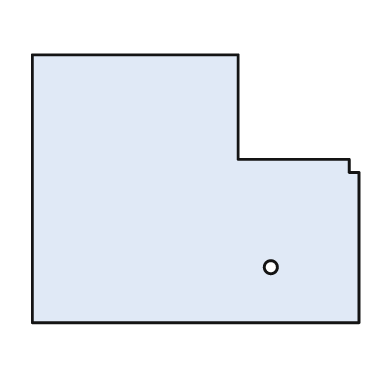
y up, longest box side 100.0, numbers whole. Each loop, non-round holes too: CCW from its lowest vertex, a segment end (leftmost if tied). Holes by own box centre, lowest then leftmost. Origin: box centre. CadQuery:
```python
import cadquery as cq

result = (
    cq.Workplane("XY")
    .moveTo(-50.0, -41.0)
    .lineTo(50.0, -41.0)
    .lineTo(50.0, 5.0)
    .lineTo(47.0, 5.0)
    .lineTo(47.0, 9.0)
    .lineTo(13.0, 9.0)
    .lineTo(13.0, 41.0)
    .lineTo(-50.0, 41.0)
    .close()
    .moveTo(23.0, -24.0)
    .circle(2.0)
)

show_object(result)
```